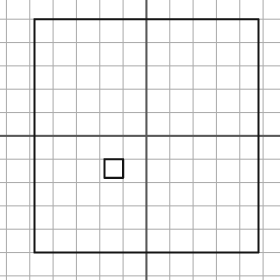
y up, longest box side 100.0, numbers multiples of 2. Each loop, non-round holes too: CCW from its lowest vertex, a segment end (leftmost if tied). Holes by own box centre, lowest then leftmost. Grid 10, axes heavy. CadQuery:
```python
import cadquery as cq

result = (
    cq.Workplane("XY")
    .moveTo(-48.0, -50.0)
    .lineTo(48.0, -50.0)
    .lineTo(48.0, 50.0)
    .lineTo(-48.0, 50.0)
    .close()
    .moveTo(-18.0, -18.0)
    .lineTo(-10.0, -18.0)
    .lineTo(-10.0, -10.0)
    .lineTo(-18.0, -10.0)
    .close()
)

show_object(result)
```